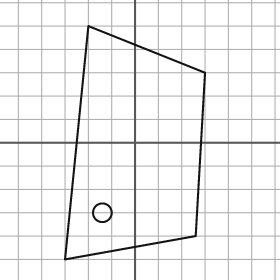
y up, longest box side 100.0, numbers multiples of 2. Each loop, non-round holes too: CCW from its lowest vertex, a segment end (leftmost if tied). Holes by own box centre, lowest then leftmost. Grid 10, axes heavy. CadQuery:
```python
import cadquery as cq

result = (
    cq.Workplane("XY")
    .moveTo(-30.0, -50.0)
    .lineTo(26.0, -40.0)
    .lineTo(30.0, 30.0)
    .lineTo(-20.0, 50.0)
    .close()
    .moveTo(-14.0, -30.0)
    .circle(4.0)
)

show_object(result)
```